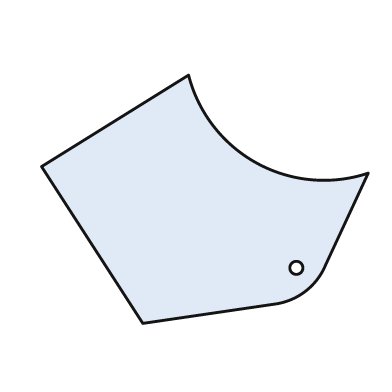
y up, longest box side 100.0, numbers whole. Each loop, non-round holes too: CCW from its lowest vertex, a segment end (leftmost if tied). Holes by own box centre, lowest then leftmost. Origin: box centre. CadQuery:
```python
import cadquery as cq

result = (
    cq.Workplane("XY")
    .moveTo(-19.0, -38.0)
    .lineTo(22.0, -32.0)
    .threePointArc((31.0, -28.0), (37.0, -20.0))
    .lineTo(50.0, 8.0)
    .threePointArc((16.0, 11.0), (-5.0, 38.0))
    .lineTo(-50.0, 10.0)
    .close()
    .moveTo(28.0, -21.0)
    .circle(2.0)
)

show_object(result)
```